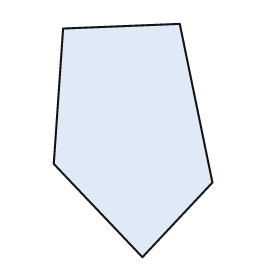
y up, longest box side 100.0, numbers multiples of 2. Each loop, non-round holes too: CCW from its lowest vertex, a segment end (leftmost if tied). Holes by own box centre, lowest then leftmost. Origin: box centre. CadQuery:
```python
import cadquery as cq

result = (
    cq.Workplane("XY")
    .moveTo(4.0, -50.0)
    .lineTo(34.0, -18.0)
    .lineTo(20.0, 50.0)
    .lineTo(-30.0, 48.0)
    .lineTo(-34.0, -10.0)
    .close()
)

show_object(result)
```